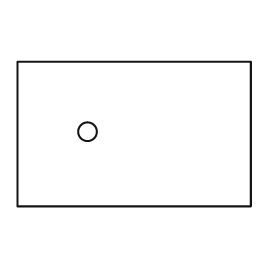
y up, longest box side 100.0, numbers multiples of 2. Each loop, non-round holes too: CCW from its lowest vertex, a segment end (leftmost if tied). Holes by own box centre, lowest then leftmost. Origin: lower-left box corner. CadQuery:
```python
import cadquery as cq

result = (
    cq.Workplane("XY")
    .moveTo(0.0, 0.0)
    .lineTo(100.0, 0.0)
    .lineTo(100.0, 62.0)
    .lineTo(0.0, 62.0)
    .close()
    .moveTo(30.0, 32.0)
    .circle(4.0)
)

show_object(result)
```